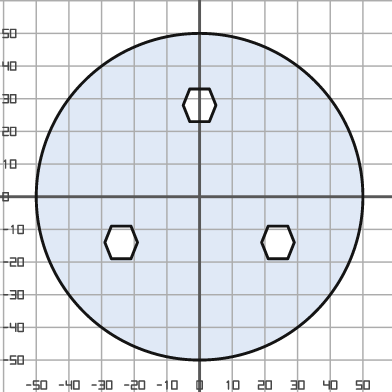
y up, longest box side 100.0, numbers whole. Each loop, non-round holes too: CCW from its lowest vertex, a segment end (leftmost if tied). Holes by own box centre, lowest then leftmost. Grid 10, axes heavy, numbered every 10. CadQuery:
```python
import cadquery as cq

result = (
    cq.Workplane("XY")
    .moveTo(0.0, 0.0)
    .circle(50.0)
    .moveTo(-27.0, -19.0)
    .lineTo(-21.0, -19.0)
    .lineTo(-19.0, -14.0)
    .lineTo(-21.0, -9.0)
    .lineTo(-27.0, -9.0)
    .lineTo(-29.0, -14.0)
    .close()
    .moveTo(21.0, -19.0)
    .lineTo(27.0, -19.0)
    .lineTo(29.0, -14.0)
    .lineTo(27.0, -9.0)
    .lineTo(21.0, -9.0)
    .lineTo(19.0, -14.0)
    .close()
    .moveTo(-3.0, 23.0)
    .lineTo(3.0, 23.0)
    .lineTo(5.0, 28.0)
    .lineTo(3.0, 33.0)
    .lineTo(-3.0, 33.0)
    .lineTo(-5.0, 28.0)
    .close()
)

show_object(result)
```